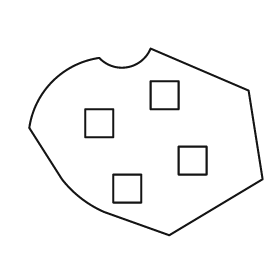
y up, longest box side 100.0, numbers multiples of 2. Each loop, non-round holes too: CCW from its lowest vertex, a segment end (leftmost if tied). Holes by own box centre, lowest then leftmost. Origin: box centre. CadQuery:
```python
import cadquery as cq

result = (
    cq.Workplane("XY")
    .moveTo(10.0, -40.0)
    .lineTo(50.0, -16.0)
    .lineTo(44.0, 22.0)
    .lineTo(2.0, 40.0)
    .threePointArc((-8.0, 32.0), (-20.0, 36.0))
    .threePointArc((-40.0, 26.0), (-50.0, 6.0))
    .lineTo(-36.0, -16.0)
    .threePointArc((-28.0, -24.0), (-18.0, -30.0))
    .close()
    .moveTo(-14.0, -26.0)
    .lineTo(-2.0, -26.0)
    .lineTo(-2.0, -14.0)
    .lineTo(-14.0, -14.0)
    .close()
    .moveTo(14.0, -14.0)
    .lineTo(26.0, -14.0)
    .lineTo(26.0, -2.0)
    .lineTo(14.0, -2.0)
    .close()
    .moveTo(-26.0, 2.0)
    .lineTo(-14.0, 2.0)
    .lineTo(-14.0, 14.0)
    .lineTo(-26.0, 14.0)
    .close()
    .moveTo(2.0, 14.0)
    .lineTo(14.0, 14.0)
    .lineTo(14.0, 26.0)
    .lineTo(2.0, 26.0)
    .close()
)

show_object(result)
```